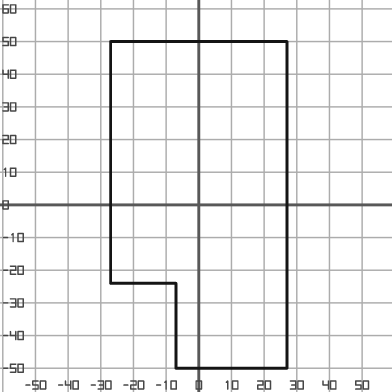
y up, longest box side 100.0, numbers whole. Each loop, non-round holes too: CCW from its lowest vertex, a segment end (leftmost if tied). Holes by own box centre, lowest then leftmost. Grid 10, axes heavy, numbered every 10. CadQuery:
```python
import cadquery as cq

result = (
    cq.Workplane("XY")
    .moveTo(-7.0, -50.0)
    .lineTo(27.0, -50.0)
    .lineTo(27.0, 50.0)
    .lineTo(-27.0, 50.0)
    .lineTo(-27.0, -24.0)
    .lineTo(-7.0, -24.0)
    .close()
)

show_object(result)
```